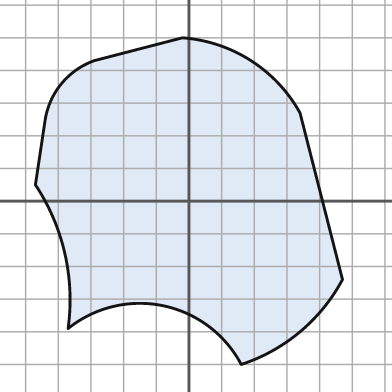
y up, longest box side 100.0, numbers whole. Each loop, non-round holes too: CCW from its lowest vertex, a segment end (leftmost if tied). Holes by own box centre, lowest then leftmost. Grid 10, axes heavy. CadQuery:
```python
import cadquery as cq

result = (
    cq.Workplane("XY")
    .moveTo(16.0, -50.0)
    .threePointArc((34.0, -40.0), (47.0, -24.0))
    .lineTo(34.0, 27.0)
    .threePointArc((19.0, 43.0), (-2.0, 50.0))
    .lineTo(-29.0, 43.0)
    .threePointArc((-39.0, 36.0), (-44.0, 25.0))
    .lineTo(-47.0, 5.0)
    .threePointArc((-38.0, -16.0), (-37.0, -39.0))
    .threePointArc((-8.0, -32.0), (16.0, -50.0))
    .close()
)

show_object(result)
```